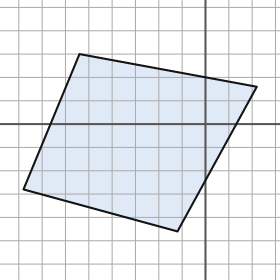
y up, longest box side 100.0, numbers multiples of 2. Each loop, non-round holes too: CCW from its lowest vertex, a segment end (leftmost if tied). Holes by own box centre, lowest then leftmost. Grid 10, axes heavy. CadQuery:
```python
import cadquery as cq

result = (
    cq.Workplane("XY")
    .moveTo(-12.0, -46.0)
    .lineTo(22.0, 16.0)
    .lineTo(-54.0, 30.0)
    .lineTo(-78.0, -28.0)
    .close()
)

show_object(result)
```